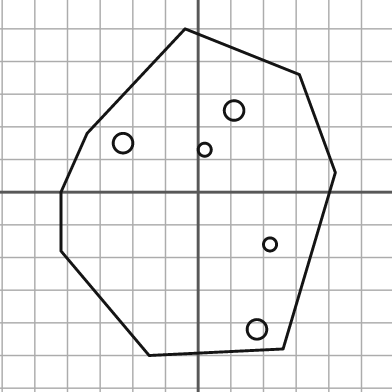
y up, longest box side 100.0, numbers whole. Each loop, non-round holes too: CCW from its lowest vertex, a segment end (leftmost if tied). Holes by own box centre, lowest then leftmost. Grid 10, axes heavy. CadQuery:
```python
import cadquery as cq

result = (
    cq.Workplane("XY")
    .moveTo(-15.0, -50.0)
    .lineTo(26.0, -48.0)
    .lineTo(42.0, 6.0)
    .lineTo(31.0, 36.0)
    .lineTo(-4.0, 50.0)
    .lineTo(-34.0, 18.0)
    .lineTo(-42.0, 0.0)
    .lineTo(-42.0, -18.0)
    .close()
    .moveTo(18.0, -42.0)
    .circle(3.0)
    .moveTo(22.0, -16.0)
    .circle(2.0)
    .moveTo(2.0, 13.0)
    .circle(2.0)
    .moveTo(-23.0, 15.0)
    .circle(3.0)
    .moveTo(11.0, 25.0)
    .circle(3.0)
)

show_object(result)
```